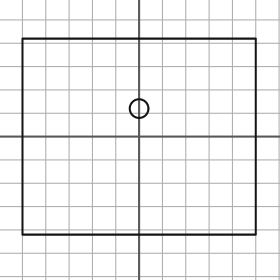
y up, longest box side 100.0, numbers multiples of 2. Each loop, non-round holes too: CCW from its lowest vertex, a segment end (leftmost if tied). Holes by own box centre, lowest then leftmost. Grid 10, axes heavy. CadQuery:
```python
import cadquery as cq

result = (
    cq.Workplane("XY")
    .moveTo(-50.0, -42.0)
    .lineTo(50.0, -42.0)
    .lineTo(50.0, 42.0)
    .lineTo(-50.0, 42.0)
    .close()
    .moveTo(0.0, 12.0)
    .circle(4.0)
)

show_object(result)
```